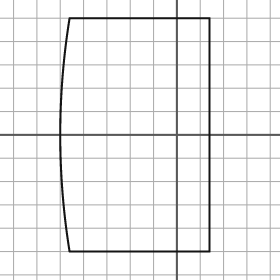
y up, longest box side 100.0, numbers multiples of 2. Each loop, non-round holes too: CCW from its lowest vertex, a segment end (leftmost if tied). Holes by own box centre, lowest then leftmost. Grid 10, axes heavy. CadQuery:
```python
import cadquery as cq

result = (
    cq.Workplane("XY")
    .moveTo(-46.0, -50.0)
    .lineTo(14.0, -50.0)
    .lineTo(14.0, 50.0)
    .lineTo(-46.0, 50.0)
    .threePointArc((-50.0, 0.0), (-46.0, -50.0))
    .close()
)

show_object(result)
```